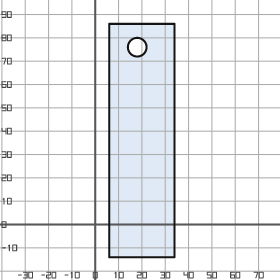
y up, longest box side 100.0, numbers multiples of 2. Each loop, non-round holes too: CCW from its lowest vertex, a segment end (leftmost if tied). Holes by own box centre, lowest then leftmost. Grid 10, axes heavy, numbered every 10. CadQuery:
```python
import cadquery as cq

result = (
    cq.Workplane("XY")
    .moveTo(6.0, -14.0)
    .lineTo(34.0, -14.0)
    .lineTo(34.0, 86.0)
    .lineTo(6.0, 86.0)
    .close()
    .moveTo(18.0, 76.0)
    .circle(4.0)
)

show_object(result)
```